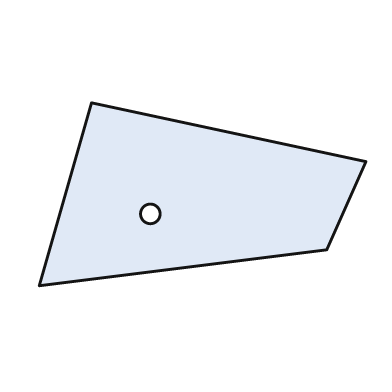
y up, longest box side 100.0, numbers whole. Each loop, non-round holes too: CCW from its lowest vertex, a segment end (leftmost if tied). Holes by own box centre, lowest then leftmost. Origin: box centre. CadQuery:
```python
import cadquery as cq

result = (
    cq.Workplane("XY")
    .moveTo(-50.0, -28.0)
    .lineTo(38.0, -17.0)
    .lineTo(50.0, 10.0)
    .lineTo(-34.0, 28.0)
    .close()
    .moveTo(-16.0, -6.0)
    .circle(3.0)
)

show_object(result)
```